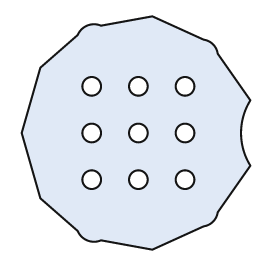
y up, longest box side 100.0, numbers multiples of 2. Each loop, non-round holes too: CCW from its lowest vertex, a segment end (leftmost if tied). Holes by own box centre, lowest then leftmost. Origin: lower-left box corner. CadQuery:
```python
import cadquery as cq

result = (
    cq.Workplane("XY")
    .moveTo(56.0, 0.0)
    .lineTo(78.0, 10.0)
    .threePointArc((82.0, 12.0), (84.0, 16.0))
    .lineTo(98.0, 36.0)
    .threePointArc((94.0, 50.0), (98.0, 64.0))
    .lineTo(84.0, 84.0)
    .threePointArc((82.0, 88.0), (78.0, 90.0))
    .lineTo(56.0, 100.0)
    .lineTo(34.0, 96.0)
    .threePointArc((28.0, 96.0), (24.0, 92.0))
    .lineTo(8.0, 78.0)
    .lineTo(0.0, 50.0)
    .lineTo(8.0, 22.0)
    .lineTo(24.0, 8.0)
    .threePointArc((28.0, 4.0), (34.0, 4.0))
    .close()
    .moveTo(30.0, 30.0)
    .circle(4.0)
    .moveTo(50.0, 30.0)
    .circle(4.0)
    .moveTo(70.0, 30.0)
    .circle(4.0)
    .moveTo(30.0, 50.0)
    .circle(4.0)
    .moveTo(50.0, 50.0)
    .circle(4.0)
    .moveTo(70.0, 50.0)
    .circle(4.0)
    .moveTo(30.0, 70.0)
    .circle(4.0)
    .moveTo(50.0, 70.0)
    .circle(4.0)
    .moveTo(70.0, 70.0)
    .circle(4.0)
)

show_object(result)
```